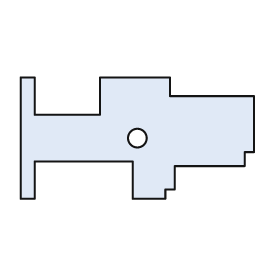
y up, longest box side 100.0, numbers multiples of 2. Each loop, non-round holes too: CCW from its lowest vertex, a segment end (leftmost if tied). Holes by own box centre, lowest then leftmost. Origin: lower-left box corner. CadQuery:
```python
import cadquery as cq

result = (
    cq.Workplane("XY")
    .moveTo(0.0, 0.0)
    .lineTo(6.0, 0.0)
    .lineTo(6.0, 16.0)
    .lineTo(48.0, 16.0)
    .lineTo(48.0, 0.0)
    .lineTo(62.0, 0.0)
    .lineTo(62.0, 4.0)
    .lineTo(66.0, 4.0)
    .lineTo(66.0, 14.0)
    .lineTo(96.0, 14.0)
    .lineTo(96.0, 20.0)
    .lineTo(100.0, 20.0)
    .lineTo(100.0, 44.0)
    .lineTo(64.0, 44.0)
    .lineTo(64.0, 52.0)
    .lineTo(34.0, 52.0)
    .lineTo(34.0, 36.0)
    .lineTo(6.0, 36.0)
    .lineTo(6.0, 52.0)
    .lineTo(0.0, 52.0)
    .close()
    .moveTo(50.0, 26.0)
    .circle(4.0)
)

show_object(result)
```